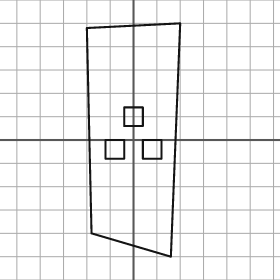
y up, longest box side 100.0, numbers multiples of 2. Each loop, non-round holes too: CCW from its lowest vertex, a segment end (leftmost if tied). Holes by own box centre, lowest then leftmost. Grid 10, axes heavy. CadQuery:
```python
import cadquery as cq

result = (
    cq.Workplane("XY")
    .moveTo(16.0, -50.0)
    .lineTo(20.0, 50.0)
    .lineTo(-20.0, 48.0)
    .lineTo(-18.0, -40.0)
    .close()
    .moveTo(-12.0, -8.0)
    .lineTo(-4.0, -8.0)
    .lineTo(-4.0, 0.0)
    .lineTo(-12.0, 0.0)
    .close()
    .moveTo(4.0, -8.0)
    .lineTo(12.0, -8.0)
    .lineTo(12.0, 0.0)
    .lineTo(4.0, 0.0)
    .close()
    .moveTo(-4.0, 6.0)
    .lineTo(4.0, 6.0)
    .lineTo(4.0, 14.0)
    .lineTo(-4.0, 14.0)
    .close()
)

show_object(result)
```